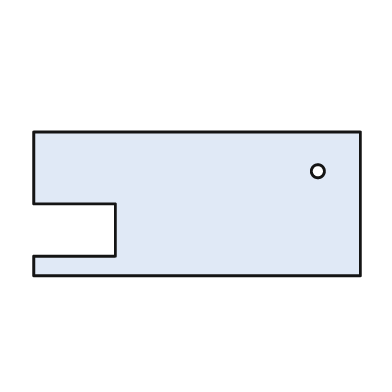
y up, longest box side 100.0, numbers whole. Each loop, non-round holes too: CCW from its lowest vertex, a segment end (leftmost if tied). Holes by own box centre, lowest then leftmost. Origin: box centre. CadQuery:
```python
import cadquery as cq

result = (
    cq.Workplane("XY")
    .moveTo(-50.0, -22.0)
    .lineTo(50.0, -22.0)
    .lineTo(50.0, 22.0)
    .lineTo(-50.0, 22.0)
    .lineTo(-50.0, 0.0)
    .lineTo(-25.0, 0.0)
    .lineTo(-25.0, -16.0)
    .lineTo(-50.0, -16.0)
    .close()
    .moveTo(37.0, 10.0)
    .circle(2.0)
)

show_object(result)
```